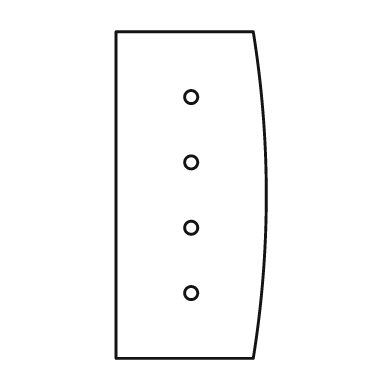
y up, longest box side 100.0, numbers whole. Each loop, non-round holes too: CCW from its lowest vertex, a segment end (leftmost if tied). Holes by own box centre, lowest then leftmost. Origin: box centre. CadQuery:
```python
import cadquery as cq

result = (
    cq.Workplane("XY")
    .moveTo(-23.0, -50.0)
    .lineTo(19.0, -50.0)
    .threePointArc((23.0, 0.0), (19.0, 50.0))
    .lineTo(-23.0, 50.0)
    .close()
    .moveTo(0.0, -30.0)
    .circle(2.0)
    .moveTo(0.0, -10.0)
    .circle(2.0)
    .moveTo(0.0, 10.0)
    .circle(2.0)
    .moveTo(0.0, 30.0)
    .circle(2.0)
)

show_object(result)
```